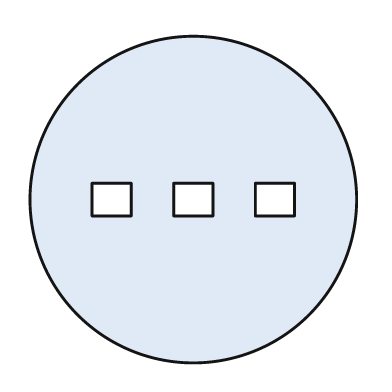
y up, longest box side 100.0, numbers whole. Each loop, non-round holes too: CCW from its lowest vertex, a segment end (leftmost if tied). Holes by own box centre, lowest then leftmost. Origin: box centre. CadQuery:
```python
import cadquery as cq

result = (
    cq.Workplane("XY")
    .moveTo(0.0, 0.0)
    .circle(50.0)
    .moveTo(-31.0, -5.0)
    .lineTo(-19.0, -5.0)
    .lineTo(-19.0, 5.0)
    .lineTo(-31.0, 5.0)
    .close()
    .moveTo(-6.0, -5.0)
    .lineTo(6.0, -5.0)
    .lineTo(6.0, 5.0)
    .lineTo(-6.0, 5.0)
    .close()
    .moveTo(19.0, -5.0)
    .lineTo(31.0, -5.0)
    .lineTo(31.0, 5.0)
    .lineTo(19.0, 5.0)
    .close()
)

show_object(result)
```